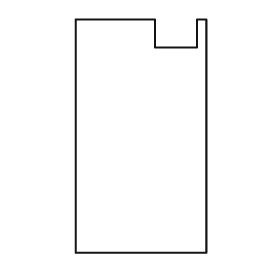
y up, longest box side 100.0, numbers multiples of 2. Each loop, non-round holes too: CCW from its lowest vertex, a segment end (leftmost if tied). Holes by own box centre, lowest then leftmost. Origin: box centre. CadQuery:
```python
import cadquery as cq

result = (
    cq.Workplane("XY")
    .moveTo(-28.0, -50.0)
    .lineTo(28.0, -50.0)
    .lineTo(28.0, 50.0)
    .lineTo(24.0, 50.0)
    .lineTo(24.0, 38.0)
    .lineTo(6.0, 38.0)
    .lineTo(6.0, 50.0)
    .lineTo(-28.0, 50.0)
    .close()
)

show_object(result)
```